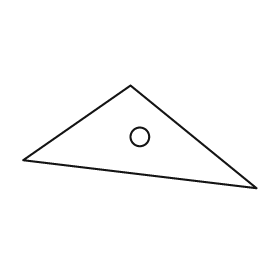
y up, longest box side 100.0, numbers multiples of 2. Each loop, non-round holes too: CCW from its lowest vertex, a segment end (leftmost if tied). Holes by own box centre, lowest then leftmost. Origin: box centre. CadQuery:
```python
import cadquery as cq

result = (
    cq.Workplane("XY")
    .moveTo(50.0, -22.0)
    .lineTo(-4.0, 22.0)
    .lineTo(-50.0, -10.0)
    .close()
    .moveTo(0.0, 0.0)
    .circle(4.0)
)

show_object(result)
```